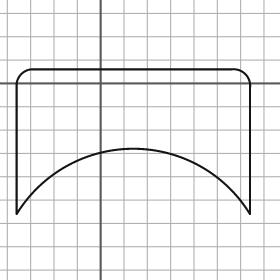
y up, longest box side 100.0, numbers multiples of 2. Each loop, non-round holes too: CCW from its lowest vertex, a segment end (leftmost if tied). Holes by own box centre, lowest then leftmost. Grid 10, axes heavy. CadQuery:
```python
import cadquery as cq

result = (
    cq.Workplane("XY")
    .moveTo(-36.0, -56.0)
    .threePointArc((14.0, -28.0), (64.0, -56.0))
    .lineTo(64.0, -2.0)
    .threePointArc((62.0, 4.0), (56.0, 6.0))
    .lineTo(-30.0, 6.0)
    .threePointArc((-34.0, 4.0), (-36.0, 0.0))
    .close()
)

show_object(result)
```